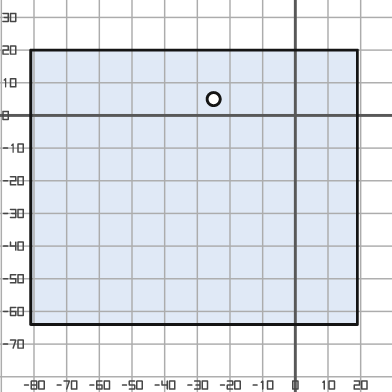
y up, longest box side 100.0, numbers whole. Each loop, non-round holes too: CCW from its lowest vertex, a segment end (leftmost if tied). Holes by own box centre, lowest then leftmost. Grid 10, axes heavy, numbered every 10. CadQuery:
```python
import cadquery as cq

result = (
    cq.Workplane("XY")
    .moveTo(-81.0, -64.0)
    .lineTo(19.0, -64.0)
    .lineTo(19.0, 20.0)
    .lineTo(-81.0, 20.0)
    .close()
    .moveTo(-25.0, 5.0)
    .circle(2.0)
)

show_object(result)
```